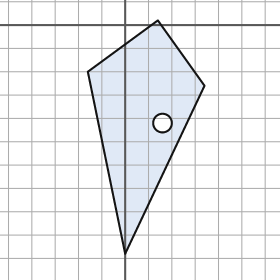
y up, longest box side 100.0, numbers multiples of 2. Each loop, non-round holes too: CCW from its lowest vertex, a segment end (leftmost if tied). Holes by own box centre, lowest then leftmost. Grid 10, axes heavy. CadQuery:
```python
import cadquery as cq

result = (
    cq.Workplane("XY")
    .moveTo(0.0, -98.0)
    .lineTo(34.0, -26.0)
    .lineTo(14.0, 2.0)
    .lineTo(-16.0, -20.0)
    .close()
    .moveTo(16.0, -42.0)
    .circle(4.0)
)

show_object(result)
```